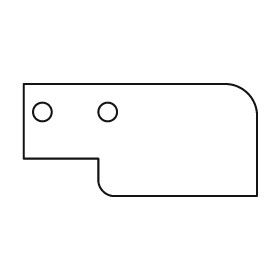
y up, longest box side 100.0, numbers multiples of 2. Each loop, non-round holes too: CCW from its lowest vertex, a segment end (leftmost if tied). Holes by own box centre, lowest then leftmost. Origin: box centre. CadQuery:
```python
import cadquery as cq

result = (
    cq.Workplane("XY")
    .moveTo(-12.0, -24.0)
    .lineTo(50.0, -24.0)
    .lineTo(50.0, 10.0)
    .threePointArc((46.0, 20.0), (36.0, 24.0))
    .lineTo(-50.0, 24.0)
    .lineTo(-50.0, -8.0)
    .lineTo(-18.0, -8.0)
    .lineTo(-18.0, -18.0)
    .threePointArc((-16.0, -22.0), (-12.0, -24.0))
    .close()
    .moveTo(-42.0, 12.0)
    .circle(4.0)
    .moveTo(-14.0, 12.0)
    .circle(4.0)
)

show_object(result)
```